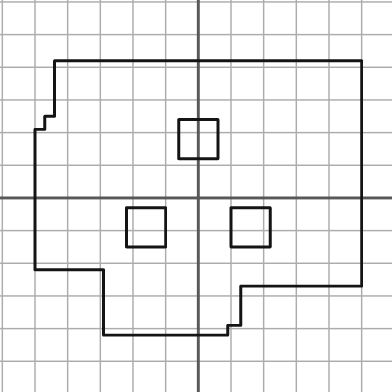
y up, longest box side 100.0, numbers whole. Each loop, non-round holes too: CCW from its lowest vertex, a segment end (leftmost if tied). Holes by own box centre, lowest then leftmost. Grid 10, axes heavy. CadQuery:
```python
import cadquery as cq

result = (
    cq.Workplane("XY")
    .moveTo(-29.0, -42.0)
    .lineTo(9.0, -42.0)
    .lineTo(9.0, -39.0)
    .lineTo(13.0, -39.0)
    .lineTo(13.0, -27.0)
    .lineTo(50.0, -27.0)
    .lineTo(50.0, 42.0)
    .lineTo(-44.0, 42.0)
    .lineTo(-44.0, 25.0)
    .lineTo(-47.0, 25.0)
    .lineTo(-47.0, 21.0)
    .lineTo(-50.0, 21.0)
    .lineTo(-50.0, -22.0)
    .lineTo(-29.0, -22.0)
    .close()
    .moveTo(-22.0, -15.0)
    .lineTo(-10.0, -15.0)
    .lineTo(-10.0, -3.0)
    .lineTo(-22.0, -3.0)
    .close()
    .moveTo(10.0, -15.0)
    .lineTo(22.0, -15.0)
    .lineTo(22.0, -3.0)
    .lineTo(10.0, -3.0)
    .close()
    .moveTo(-6.0, 12.0)
    .lineTo(6.0, 12.0)
    .lineTo(6.0, 24.0)
    .lineTo(-6.0, 24.0)
    .close()
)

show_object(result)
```